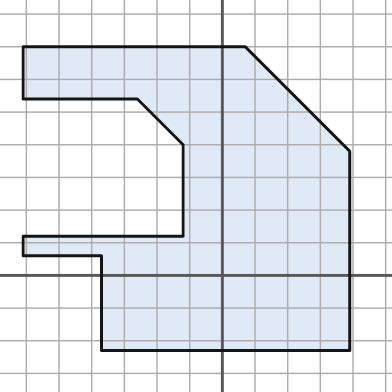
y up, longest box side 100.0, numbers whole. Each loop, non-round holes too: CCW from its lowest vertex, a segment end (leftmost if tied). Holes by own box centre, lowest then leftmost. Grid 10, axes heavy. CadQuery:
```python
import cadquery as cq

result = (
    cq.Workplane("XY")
    .moveTo(-37.0, -23.0)
    .lineTo(39.0, -23.0)
    .lineTo(39.0, 38.0)
    .lineTo(7.0, 70.0)
    .lineTo(-61.0, 70.0)
    .lineTo(-61.0, 54.0)
    .lineTo(-26.0, 54.0)
    .lineTo(-12.0, 40.0)
    .lineTo(-12.0, 12.0)
    .lineTo(-61.0, 12.0)
    .lineTo(-61.0, 6.0)
    .lineTo(-37.0, 6.0)
    .close()
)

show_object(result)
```